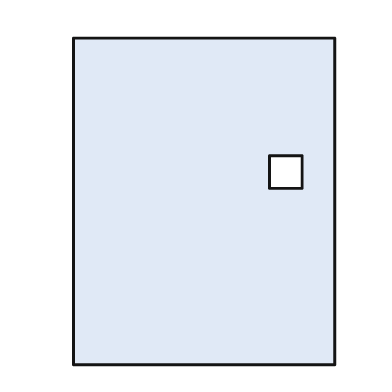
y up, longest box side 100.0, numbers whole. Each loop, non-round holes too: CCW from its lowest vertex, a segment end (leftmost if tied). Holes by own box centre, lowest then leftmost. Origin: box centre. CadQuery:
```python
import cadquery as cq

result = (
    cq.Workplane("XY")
    .moveTo(-40.0, -50.0)
    .lineTo(40.0, -50.0)
    .lineTo(40.0, 50.0)
    .lineTo(-40.0, 50.0)
    .close()
    .moveTo(20.0, 4.0)
    .lineTo(30.0, 4.0)
    .lineTo(30.0, 14.0)
    .lineTo(20.0, 14.0)
    .close()
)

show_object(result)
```